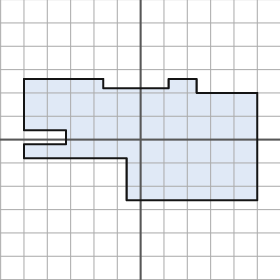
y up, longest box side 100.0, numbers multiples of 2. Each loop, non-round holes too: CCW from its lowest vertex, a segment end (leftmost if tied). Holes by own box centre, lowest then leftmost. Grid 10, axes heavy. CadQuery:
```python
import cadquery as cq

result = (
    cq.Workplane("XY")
    .moveTo(-6.0, -26.0)
    .lineTo(50.0, -26.0)
    .lineTo(50.0, 20.0)
    .lineTo(24.0, 20.0)
    .lineTo(24.0, 26.0)
    .lineTo(12.0, 26.0)
    .lineTo(12.0, 22.0)
    .lineTo(-16.0, 22.0)
    .lineTo(-16.0, 26.0)
    .lineTo(-50.0, 26.0)
    .lineTo(-50.0, 4.0)
    .lineTo(-32.0, 4.0)
    .lineTo(-32.0, -2.0)
    .lineTo(-50.0, -2.0)
    .lineTo(-50.0, -8.0)
    .lineTo(-6.0, -8.0)
    .close()
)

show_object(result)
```